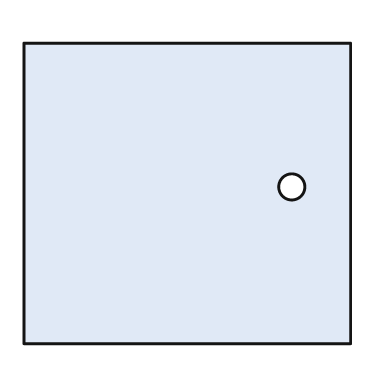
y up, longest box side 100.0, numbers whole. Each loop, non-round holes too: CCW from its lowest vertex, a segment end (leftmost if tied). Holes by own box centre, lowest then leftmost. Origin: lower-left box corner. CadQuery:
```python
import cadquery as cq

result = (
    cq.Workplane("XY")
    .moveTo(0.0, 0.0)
    .lineTo(100.0, 0.0)
    .lineTo(100.0, 92.0)
    .lineTo(0.0, 92.0)
    .close()
    .moveTo(82.0, 48.0)
    .circle(4.0)
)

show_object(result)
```